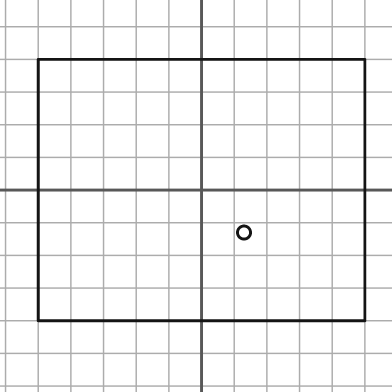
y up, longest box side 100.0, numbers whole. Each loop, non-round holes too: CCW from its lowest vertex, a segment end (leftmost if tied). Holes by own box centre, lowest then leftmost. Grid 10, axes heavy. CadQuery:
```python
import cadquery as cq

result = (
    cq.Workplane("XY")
    .moveTo(-50.0, -40.0)
    .lineTo(50.0, -40.0)
    .lineTo(50.0, 40.0)
    .lineTo(-50.0, 40.0)
    .close()
    .moveTo(13.0, -13.0)
    .circle(2.0)
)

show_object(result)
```